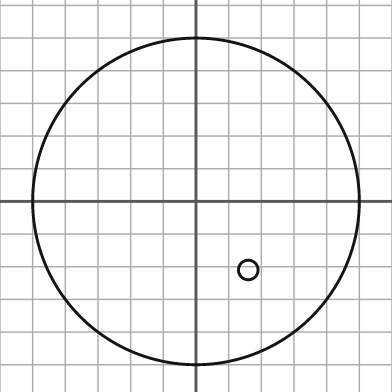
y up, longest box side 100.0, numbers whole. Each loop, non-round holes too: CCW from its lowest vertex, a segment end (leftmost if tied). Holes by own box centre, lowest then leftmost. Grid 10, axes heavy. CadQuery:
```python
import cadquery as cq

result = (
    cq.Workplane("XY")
    .moveTo(0.0, 0.0)
    .circle(50.0)
    .moveTo(16.0, -21.0)
    .circle(3.0)
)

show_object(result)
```